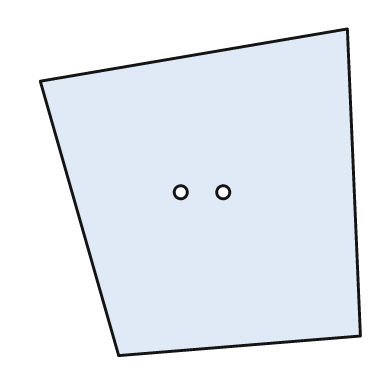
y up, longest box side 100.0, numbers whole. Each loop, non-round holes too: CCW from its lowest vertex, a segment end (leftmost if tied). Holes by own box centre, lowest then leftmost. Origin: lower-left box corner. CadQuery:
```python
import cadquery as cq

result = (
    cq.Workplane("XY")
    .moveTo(24.0, 0.0)
    .lineTo(98.0, 6.0)
    .lineTo(94.0, 100.0)
    .lineTo(0.0, 84.0)
    .close()
    .moveTo(43.0, 50.0)
    .circle(2.0)
    .moveTo(56.0, 50.0)
    .circle(2.0)
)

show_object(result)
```